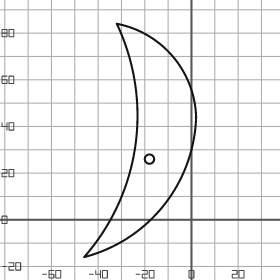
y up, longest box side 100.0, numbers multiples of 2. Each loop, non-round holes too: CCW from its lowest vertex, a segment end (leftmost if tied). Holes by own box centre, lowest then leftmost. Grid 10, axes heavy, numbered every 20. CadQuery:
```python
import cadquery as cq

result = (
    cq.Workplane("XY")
    .moveTo(-46.0, -16.0)
    .threePointArc((-12.0, 6.0), (2.0, 44.0))
    .threePointArc((-8.0, 70.0), (-32.0, 84.0))
    .threePointArc((-24.0, 32.0), (-46.0, -16.0))
    .close()
    .moveTo(-18.0, 26.0)
    .circle(2.0)
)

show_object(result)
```